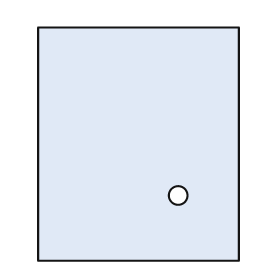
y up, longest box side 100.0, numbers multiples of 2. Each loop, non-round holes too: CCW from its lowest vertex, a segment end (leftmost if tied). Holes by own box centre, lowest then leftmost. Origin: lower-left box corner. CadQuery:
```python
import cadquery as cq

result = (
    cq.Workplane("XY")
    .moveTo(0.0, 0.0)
    .lineTo(86.0, 0.0)
    .lineTo(86.0, 100.0)
    .lineTo(0.0, 100.0)
    .close()
    .moveTo(60.0, 28.0)
    .circle(4.0)
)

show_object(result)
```